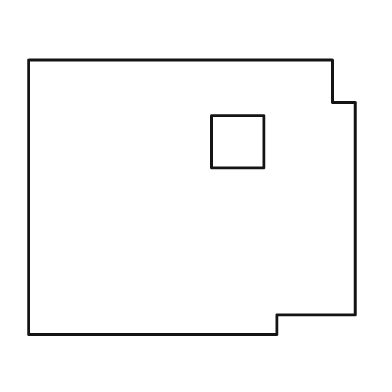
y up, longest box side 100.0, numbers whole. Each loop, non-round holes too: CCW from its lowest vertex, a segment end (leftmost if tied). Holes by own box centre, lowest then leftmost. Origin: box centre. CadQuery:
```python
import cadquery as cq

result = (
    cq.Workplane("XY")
    .moveTo(-50.0, -42.0)
    .lineTo(26.0, -42.0)
    .lineTo(26.0, -36.0)
    .lineTo(50.0, -36.0)
    .lineTo(50.0, 29.0)
    .lineTo(43.0, 29.0)
    .lineTo(43.0, 42.0)
    .lineTo(-50.0, 42.0)
    .close()
    .moveTo(6.0, 9.0)
    .lineTo(22.0, 9.0)
    .lineTo(22.0, 25.0)
    .lineTo(6.0, 25.0)
    .close()
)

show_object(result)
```